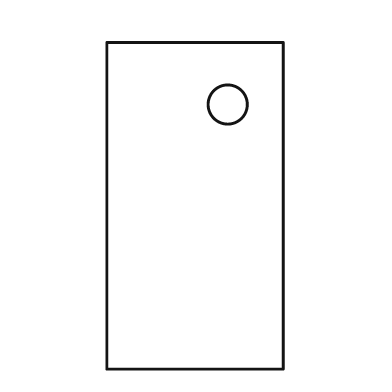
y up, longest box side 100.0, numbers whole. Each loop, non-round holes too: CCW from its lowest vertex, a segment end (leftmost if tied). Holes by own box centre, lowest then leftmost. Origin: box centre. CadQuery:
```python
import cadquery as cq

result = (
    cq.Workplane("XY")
    .moveTo(-27.0, -50.0)
    .lineTo(27.0, -50.0)
    .lineTo(27.0, 50.0)
    .lineTo(-27.0, 50.0)
    .close()
    .moveTo(10.0, 31.0)
    .circle(6.0)
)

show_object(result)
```